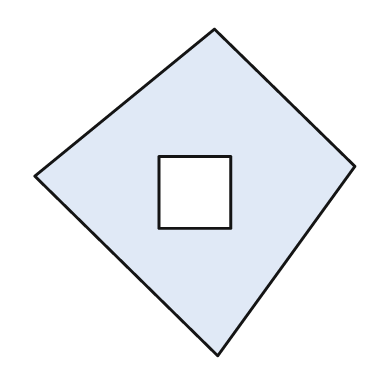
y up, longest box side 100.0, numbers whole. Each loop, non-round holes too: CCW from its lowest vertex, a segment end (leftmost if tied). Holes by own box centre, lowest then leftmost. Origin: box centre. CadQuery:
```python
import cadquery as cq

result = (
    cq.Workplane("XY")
    .moveTo(7.0, -50.0)
    .lineTo(49.0, 8.0)
    .lineTo(6.0, 50.0)
    .lineTo(-49.0, 5.0)
    .close()
    .moveTo(-11.0, -11.0)
    .lineTo(11.0, -11.0)
    .lineTo(11.0, 11.0)
    .lineTo(-11.0, 11.0)
    .close()
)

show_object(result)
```